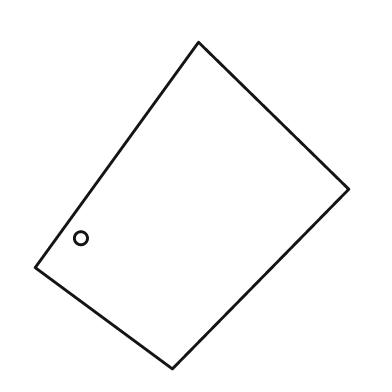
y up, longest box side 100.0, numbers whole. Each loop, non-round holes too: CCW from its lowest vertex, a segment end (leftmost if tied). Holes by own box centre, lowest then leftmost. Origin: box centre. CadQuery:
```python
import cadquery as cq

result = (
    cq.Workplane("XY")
    .moveTo(-6.0, -50.0)
    .lineTo(48.0, 5.0)
    .lineTo(2.0, 50.0)
    .lineTo(-48.0, -19.0)
    .close()
    .moveTo(-34.0, -10.0)
    .circle(2.0)
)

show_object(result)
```